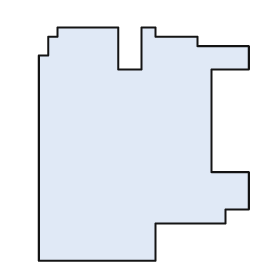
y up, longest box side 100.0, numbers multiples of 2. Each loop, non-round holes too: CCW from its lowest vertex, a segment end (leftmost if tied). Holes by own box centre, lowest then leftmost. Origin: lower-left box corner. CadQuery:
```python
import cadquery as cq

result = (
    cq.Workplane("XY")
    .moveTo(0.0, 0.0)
    .lineTo(50.0, 0.0)
    .lineTo(50.0, 16.0)
    .lineTo(80.0, 16.0)
    .lineTo(80.0, 22.0)
    .lineTo(90.0, 22.0)
    .lineTo(90.0, 38.0)
    .lineTo(74.0, 38.0)
    .lineTo(74.0, 82.0)
    .lineTo(90.0, 82.0)
    .lineTo(90.0, 92.0)
    .lineTo(68.0, 92.0)
    .lineTo(68.0, 96.0)
    .lineTo(50.0, 96.0)
    .lineTo(50.0, 100.0)
    .lineTo(44.0, 100.0)
    .lineTo(44.0, 82.0)
    .lineTo(34.0, 82.0)
    .lineTo(34.0, 100.0)
    .lineTo(8.0, 100.0)
    .lineTo(8.0, 96.0)
    .lineTo(4.0, 96.0)
    .lineTo(4.0, 88.0)
    .lineTo(0.0, 88.0)
    .close()
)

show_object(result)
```